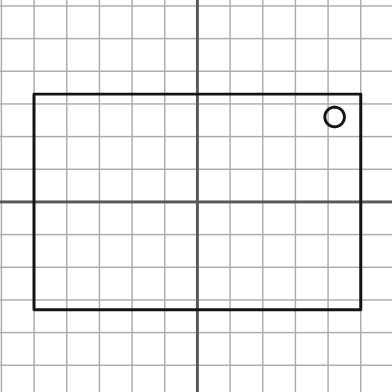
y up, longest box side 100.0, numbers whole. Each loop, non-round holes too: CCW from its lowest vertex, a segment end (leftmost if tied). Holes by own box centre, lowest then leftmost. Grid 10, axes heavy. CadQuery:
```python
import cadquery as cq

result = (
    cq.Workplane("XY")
    .moveTo(-50.0, -33.0)
    .lineTo(50.0, -33.0)
    .lineTo(50.0, 33.0)
    .lineTo(-50.0, 33.0)
    .close()
    .moveTo(42.0, 26.0)
    .circle(3.0)
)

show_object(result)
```